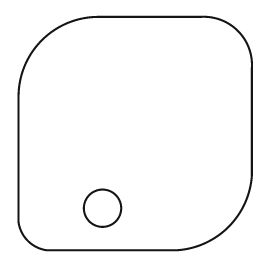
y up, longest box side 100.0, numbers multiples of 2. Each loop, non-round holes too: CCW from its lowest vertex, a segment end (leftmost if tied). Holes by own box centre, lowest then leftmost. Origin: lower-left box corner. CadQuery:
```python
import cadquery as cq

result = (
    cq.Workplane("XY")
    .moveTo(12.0, 0.0)
    .lineTo(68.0, 0.0)
    .threePointArc((90.0, 10.0), (100.0, 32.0))
    .lineTo(100.0, 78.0)
    .threePointArc((94.0, 94.0), (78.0, 100.0))
    .lineTo(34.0, 100.0)
    .threePointArc((10.0, 90.0), (0.0, 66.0))
    .lineTo(0.0, 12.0)
    .threePointArc((4.0, 4.0), (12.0, 0.0))
    .close()
    .moveTo(36.0, 18.0)
    .circle(8.0)
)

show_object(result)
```